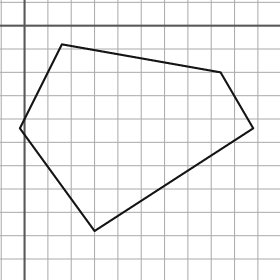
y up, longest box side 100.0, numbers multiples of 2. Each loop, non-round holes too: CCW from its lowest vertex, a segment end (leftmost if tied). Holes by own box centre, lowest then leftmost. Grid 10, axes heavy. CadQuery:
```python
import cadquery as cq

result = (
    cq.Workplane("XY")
    .moveTo(30.0, -88.0)
    .lineTo(98.0, -44.0)
    .lineTo(84.0, -20.0)
    .lineTo(16.0, -8.0)
    .lineTo(-2.0, -44.0)
    .close()
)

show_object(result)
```